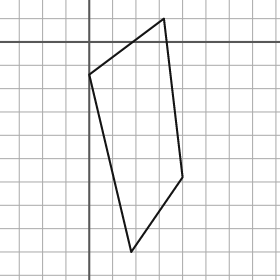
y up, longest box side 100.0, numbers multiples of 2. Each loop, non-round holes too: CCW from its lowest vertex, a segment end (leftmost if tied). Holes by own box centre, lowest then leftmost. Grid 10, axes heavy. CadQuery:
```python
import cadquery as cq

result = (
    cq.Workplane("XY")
    .moveTo(18.0, -90.0)
    .lineTo(40.0, -58.0)
    .lineTo(32.0, 10.0)
    .lineTo(0.0, -14.0)
    .close()
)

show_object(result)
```